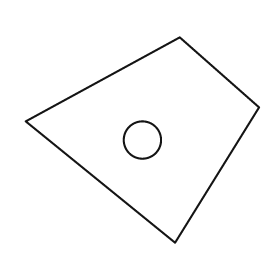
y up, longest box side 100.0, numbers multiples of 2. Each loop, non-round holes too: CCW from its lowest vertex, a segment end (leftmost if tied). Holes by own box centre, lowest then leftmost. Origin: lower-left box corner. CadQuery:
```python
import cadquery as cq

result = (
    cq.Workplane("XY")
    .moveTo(64.0, 0.0)
    .lineTo(100.0, 58.0)
    .lineTo(66.0, 88.0)
    .lineTo(0.0, 52.0)
    .close()
    .moveTo(50.0, 44.0)
    .circle(8.0)
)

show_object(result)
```